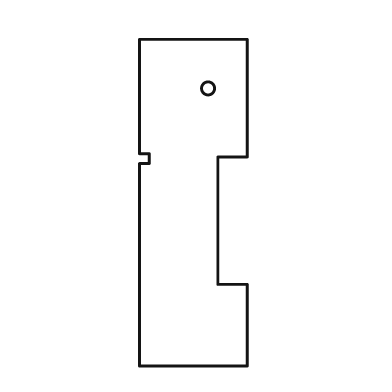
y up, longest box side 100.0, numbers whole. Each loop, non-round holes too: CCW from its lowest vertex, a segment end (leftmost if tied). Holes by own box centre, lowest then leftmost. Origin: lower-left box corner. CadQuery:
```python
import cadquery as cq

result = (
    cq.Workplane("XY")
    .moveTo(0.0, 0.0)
    .lineTo(33.0, 0.0)
    .lineTo(33.0, 25.0)
    .lineTo(24.0, 25.0)
    .lineTo(24.0, 64.0)
    .lineTo(33.0, 64.0)
    .lineTo(33.0, 100.0)
    .lineTo(0.0, 100.0)
    .lineTo(0.0, 65.0)
    .lineTo(3.0, 65.0)
    .lineTo(3.0, 62.0)
    .lineTo(0.0, 62.0)
    .close()
    .moveTo(21.0, 85.0)
    .circle(2.0)
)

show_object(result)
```